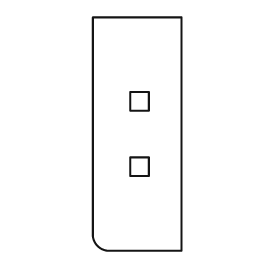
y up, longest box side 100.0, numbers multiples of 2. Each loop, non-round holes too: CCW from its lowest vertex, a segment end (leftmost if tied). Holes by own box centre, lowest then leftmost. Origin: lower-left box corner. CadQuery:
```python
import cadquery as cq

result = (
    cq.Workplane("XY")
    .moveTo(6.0, 0.0)
    .lineTo(38.0, 0.0)
    .lineTo(38.0, 100.0)
    .lineTo(0.0, 100.0)
    .lineTo(0.0, 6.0)
    .threePointArc((2.0, 2.0), (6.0, 0.0))
    .close()
    .moveTo(16.0, 32.0)
    .lineTo(24.0, 32.0)
    .lineTo(24.0, 40.0)
    .lineTo(16.0, 40.0)
    .close()
    .moveTo(16.0, 60.0)
    .lineTo(24.0, 60.0)
    .lineTo(24.0, 68.0)
    .lineTo(16.0, 68.0)
    .close()
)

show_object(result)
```